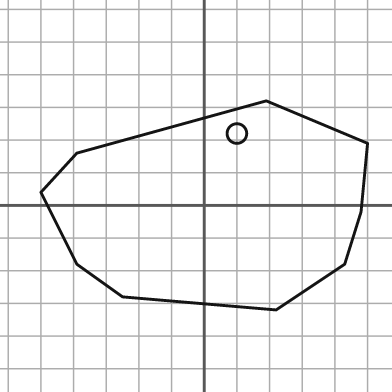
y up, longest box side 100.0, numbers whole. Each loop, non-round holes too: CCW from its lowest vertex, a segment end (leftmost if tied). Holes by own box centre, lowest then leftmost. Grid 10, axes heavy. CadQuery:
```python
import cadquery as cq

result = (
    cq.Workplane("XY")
    .moveTo(22.0, -32.0)
    .lineTo(43.0, -18.0)
    .lineTo(48.0, -2.0)
    .lineTo(50.0, 19.0)
    .lineTo(19.0, 32.0)
    .lineTo(-39.0, 16.0)
    .lineTo(-50.0, 4.0)
    .lineTo(-39.0, -18.0)
    .lineTo(-25.0, -28.0)
    .close()
    .moveTo(10.0, 22.0)
    .circle(3.0)
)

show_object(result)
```